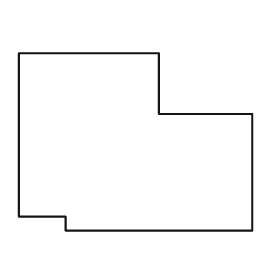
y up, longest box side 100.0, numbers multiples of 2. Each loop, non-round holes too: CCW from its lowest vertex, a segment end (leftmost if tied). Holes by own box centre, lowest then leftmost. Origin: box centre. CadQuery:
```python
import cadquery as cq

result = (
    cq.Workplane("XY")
    .moveTo(-30.0, -38.0)
    .lineTo(50.0, -38.0)
    .lineTo(50.0, 12.0)
    .lineTo(10.0, 12.0)
    .lineTo(10.0, 38.0)
    .lineTo(-50.0, 38.0)
    .lineTo(-50.0, -32.0)
    .lineTo(-30.0, -32.0)
    .close()
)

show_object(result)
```